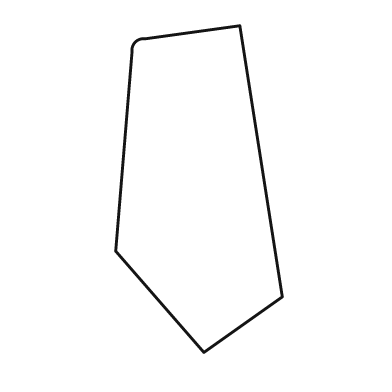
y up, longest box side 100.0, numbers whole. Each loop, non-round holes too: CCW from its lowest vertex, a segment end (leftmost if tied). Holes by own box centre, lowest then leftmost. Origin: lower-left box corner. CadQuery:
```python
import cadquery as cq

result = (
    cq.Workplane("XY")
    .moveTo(27.0, 0.0)
    .lineTo(51.0, 17.0)
    .lineTo(38.0, 100.0)
    .lineTo(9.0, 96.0)
    .threePointArc((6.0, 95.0), (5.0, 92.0))
    .lineTo(0.0, 31.0)
    .close()
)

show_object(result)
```